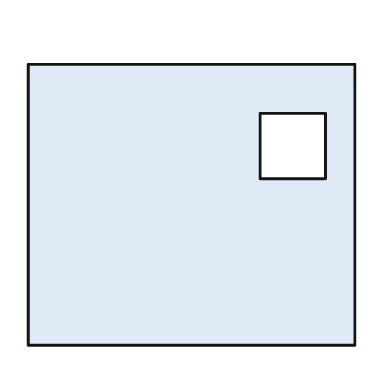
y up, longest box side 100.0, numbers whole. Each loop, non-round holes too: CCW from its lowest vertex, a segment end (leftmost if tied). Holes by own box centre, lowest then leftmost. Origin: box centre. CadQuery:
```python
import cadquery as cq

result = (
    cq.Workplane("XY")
    .moveTo(-50.0, -43.0)
    .lineTo(50.0, -43.0)
    .lineTo(50.0, 43.0)
    .lineTo(-50.0, 43.0)
    .close()
    .moveTo(21.0, 8.0)
    .lineTo(41.0, 8.0)
    .lineTo(41.0, 28.0)
    .lineTo(21.0, 28.0)
    .close()
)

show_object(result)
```